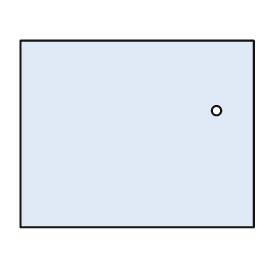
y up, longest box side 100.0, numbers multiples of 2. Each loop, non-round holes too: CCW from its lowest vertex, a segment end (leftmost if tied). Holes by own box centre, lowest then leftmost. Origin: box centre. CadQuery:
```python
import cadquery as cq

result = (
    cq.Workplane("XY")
    .moveTo(-50.0, -40.0)
    .lineTo(50.0, -40.0)
    .lineTo(50.0, 40.0)
    .lineTo(-50.0, 40.0)
    .close()
    .moveTo(34.0, 10.0)
    .circle(2.0)
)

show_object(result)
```